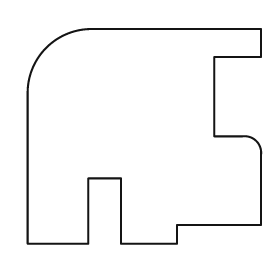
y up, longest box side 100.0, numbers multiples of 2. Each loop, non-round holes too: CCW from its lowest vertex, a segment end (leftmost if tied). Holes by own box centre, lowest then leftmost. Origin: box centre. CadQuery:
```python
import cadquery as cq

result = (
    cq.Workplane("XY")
    .moveTo(-50.0, -46.0)
    .lineTo(-24.0, -46.0)
    .lineTo(-24.0, -18.0)
    .lineTo(-10.0, -18.0)
    .lineTo(-10.0, -46.0)
    .lineTo(14.0, -46.0)
    .lineTo(14.0, -38.0)
    .lineTo(50.0, -38.0)
    .lineTo(50.0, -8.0)
    .threePointArc((48.0, -2.0), (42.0, 0.0))
    .lineTo(30.0, 0.0)
    .lineTo(30.0, 34.0)
    .lineTo(50.0, 34.0)
    .lineTo(50.0, 46.0)
    .lineTo(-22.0, 46.0)
    .threePointArc((-42.0, 38.0), (-50.0, 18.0))
    .close()
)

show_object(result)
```